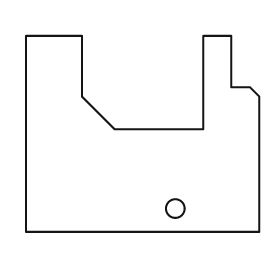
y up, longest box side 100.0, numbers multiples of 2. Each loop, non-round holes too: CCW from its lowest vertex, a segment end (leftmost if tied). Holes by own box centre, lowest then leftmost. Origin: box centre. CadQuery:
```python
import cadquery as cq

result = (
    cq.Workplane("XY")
    .moveTo(-50.0, -42.0)
    .lineTo(50.0, -42.0)
    .lineTo(50.0, 16.0)
    .lineTo(46.0, 20.0)
    .lineTo(38.0, 20.0)
    .lineTo(38.0, 42.0)
    .lineTo(26.0, 42.0)
    .lineTo(26.0, 2.0)
    .lineTo(-12.0, 2.0)
    .lineTo(-26.0, 16.0)
    .lineTo(-26.0, 42.0)
    .lineTo(-50.0, 42.0)
    .close()
    .moveTo(14.0, -32.0)
    .circle(4.0)
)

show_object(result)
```